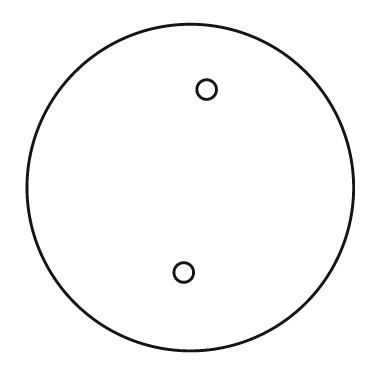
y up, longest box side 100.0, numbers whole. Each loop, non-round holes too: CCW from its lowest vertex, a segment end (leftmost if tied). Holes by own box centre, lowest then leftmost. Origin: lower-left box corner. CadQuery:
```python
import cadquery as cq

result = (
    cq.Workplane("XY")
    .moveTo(50.0, 50.0)
    .circle(50.0)
    .moveTo(48.0, 24.0)
    .circle(3.0)
    .moveTo(55.0, 80.0)
    .circle(3.0)
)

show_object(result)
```